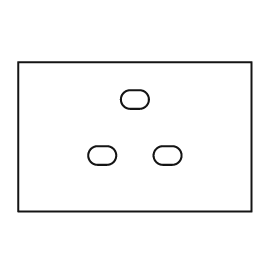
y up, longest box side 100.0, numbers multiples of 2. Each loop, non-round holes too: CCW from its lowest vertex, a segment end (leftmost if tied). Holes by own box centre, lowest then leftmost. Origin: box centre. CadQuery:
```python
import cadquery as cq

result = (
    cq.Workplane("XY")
    .moveTo(-50.0, -32.0)
    .lineTo(50.0, -32.0)
    .lineTo(50.0, 32.0)
    .lineTo(-50.0, 32.0)
    .close()
    .moveTo(-16.0, -12.0)
    .lineTo(-12.0, -12.0)
    .threePointArc((-8.0, -8.0), (-12.0, -4.0))
    .lineTo(-16.0, -4.0)
    .threePointArc((-20.0, -8.0), (-16.0, -12.0))
    .close()
    .moveTo(12.0, -12.0)
    .lineTo(16.0, -12.0)
    .threePointArc((20.0, -8.0), (16.0, -4.0))
    .lineTo(12.0, -4.0)
    .threePointArc((8.0, -8.0), (12.0, -12.0))
    .close()
    .moveTo(-2.0, 12.0)
    .lineTo(2.0, 12.0)
    .threePointArc((6.0, 16.0), (2.0, 20.0))
    .lineTo(-2.0, 20.0)
    .threePointArc((-6.0, 16.0), (-2.0, 12.0))
    .close()
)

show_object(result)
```